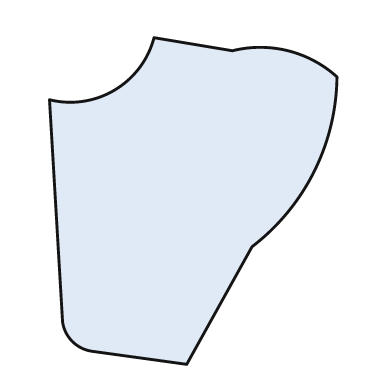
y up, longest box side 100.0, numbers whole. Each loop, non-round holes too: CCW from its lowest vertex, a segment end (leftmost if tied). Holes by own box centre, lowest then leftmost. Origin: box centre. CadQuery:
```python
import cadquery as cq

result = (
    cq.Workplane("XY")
    .moveTo(-2.0, -50.0)
    .lineTo(18.0, -14.0)
    .threePointArc((37.0, 9.0), (44.0, 38.0))
    .threePointArc((29.0, 46.0), (12.0, 46.0))
    .lineTo(-12.0, 50.0)
    .threePointArc((-24.0, 34.0), (-44.0, 31.0))
    .lineTo(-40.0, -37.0)
    .threePointArc((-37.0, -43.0), (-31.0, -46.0))
    .close()
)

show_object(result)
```